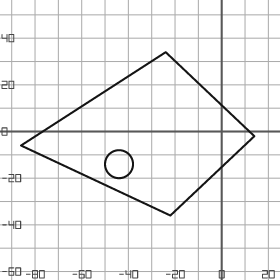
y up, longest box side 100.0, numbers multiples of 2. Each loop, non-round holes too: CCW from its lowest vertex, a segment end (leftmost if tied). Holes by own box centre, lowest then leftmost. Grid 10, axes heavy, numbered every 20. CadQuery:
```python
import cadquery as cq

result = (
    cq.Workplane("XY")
    .moveTo(-22.0, -36.0)
    .lineTo(14.0, -2.0)
    .lineTo(-24.0, 34.0)
    .lineTo(-86.0, -6.0)
    .close()
    .moveTo(-44.0, -14.0)
    .circle(6.0)
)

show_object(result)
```